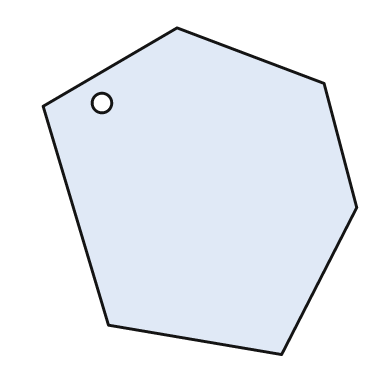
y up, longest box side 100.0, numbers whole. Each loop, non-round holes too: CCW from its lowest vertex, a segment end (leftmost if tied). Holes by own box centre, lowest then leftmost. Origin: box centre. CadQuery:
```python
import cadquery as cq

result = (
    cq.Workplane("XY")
    .moveTo(25.0, -50.0)
    .lineTo(48.0, -5.0)
    .lineTo(38.0, 33.0)
    .lineTo(-7.0, 50.0)
    .lineTo(-48.0, 26.0)
    .lineTo(-28.0, -41.0)
    .close()
    .moveTo(-30.0, 27.0)
    .circle(3.0)
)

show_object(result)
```